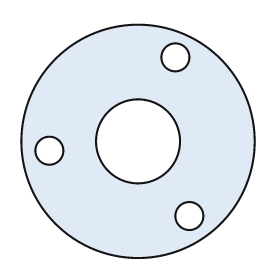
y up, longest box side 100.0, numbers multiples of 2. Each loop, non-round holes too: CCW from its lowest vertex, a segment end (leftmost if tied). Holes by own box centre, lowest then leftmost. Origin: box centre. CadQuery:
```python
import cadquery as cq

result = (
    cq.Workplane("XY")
    .moveTo(0.0, 0.0)
    .circle(50.0)
    .moveTo(22.0, -32.0)
    .circle(6.0)
    .moveTo(-38.0, -4.0)
    .circle(6.0)
    .moveTo(0.0, 0.0)
    .circle(18.0)
    .moveTo(16.0, 36.0)
    .circle(6.0)
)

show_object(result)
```